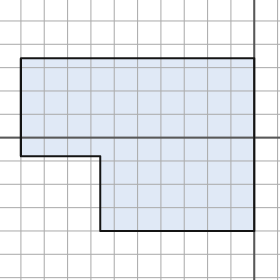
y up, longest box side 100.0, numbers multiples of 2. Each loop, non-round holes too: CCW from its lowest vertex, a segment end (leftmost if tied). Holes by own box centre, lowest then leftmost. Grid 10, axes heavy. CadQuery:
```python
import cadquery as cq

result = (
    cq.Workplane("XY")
    .moveTo(-66.0, -40.0)
    .lineTo(0.0, -40.0)
    .lineTo(0.0, 34.0)
    .lineTo(-100.0, 34.0)
    .lineTo(-100.0, -8.0)
    .lineTo(-66.0, -8.0)
    .close()
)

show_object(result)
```